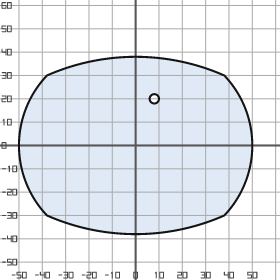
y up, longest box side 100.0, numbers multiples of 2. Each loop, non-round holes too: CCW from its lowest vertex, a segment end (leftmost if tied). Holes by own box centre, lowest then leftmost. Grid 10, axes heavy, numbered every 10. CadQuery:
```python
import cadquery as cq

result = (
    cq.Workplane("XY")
    .moveTo(-38.0, -30.0)
    .threePointArc((0.0, -38.0), (38.0, -30.0))
    .threePointArc((50.0, 0.0), (38.0, 30.0))
    .threePointArc((0.0, 38.0), (-38.0, 30.0))
    .threePointArc((-50.0, 0.0), (-38.0, -30.0))
    .close()
    .moveTo(8.0, 20.0)
    .circle(2.0)
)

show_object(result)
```